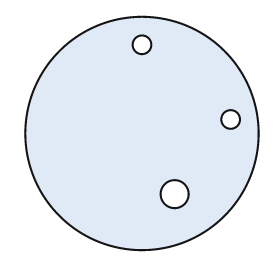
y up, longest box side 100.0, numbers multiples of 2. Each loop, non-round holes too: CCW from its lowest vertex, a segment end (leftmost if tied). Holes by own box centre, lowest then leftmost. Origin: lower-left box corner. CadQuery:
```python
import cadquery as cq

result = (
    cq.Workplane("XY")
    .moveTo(50.0, 50.0)
    .circle(50.0)
    .moveTo(64.0, 24.0)
    .circle(6.0)
    .moveTo(88.0, 56.0)
    .circle(4.0)
    .moveTo(50.0, 88.0)
    .circle(4.0)
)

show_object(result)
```